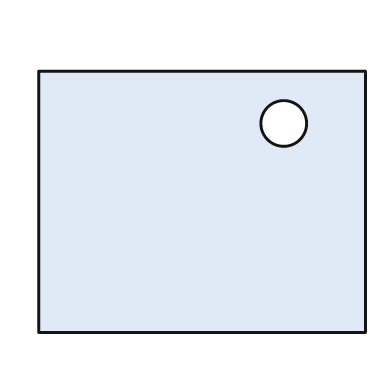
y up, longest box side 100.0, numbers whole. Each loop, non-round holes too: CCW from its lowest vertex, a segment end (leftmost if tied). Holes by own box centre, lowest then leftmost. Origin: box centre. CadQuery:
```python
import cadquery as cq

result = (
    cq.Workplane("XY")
    .moveTo(-50.0, -40.0)
    .lineTo(50.0, -40.0)
    .lineTo(50.0, 40.0)
    .lineTo(-50.0, 40.0)
    .close()
    .moveTo(25.0, 24.0)
    .circle(7.0)
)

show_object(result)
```